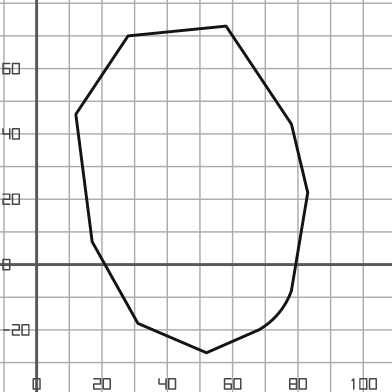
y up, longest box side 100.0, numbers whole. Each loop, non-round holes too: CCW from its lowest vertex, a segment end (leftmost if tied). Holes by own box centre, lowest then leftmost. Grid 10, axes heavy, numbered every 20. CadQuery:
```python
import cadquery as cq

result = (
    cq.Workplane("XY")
    .moveTo(52.0, -27.0)
    .lineTo(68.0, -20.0)
    .threePointArc((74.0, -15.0), (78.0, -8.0))
    .lineTo(83.0, 22.0)
    .lineTo(78.0, 43.0)
    .lineTo(58.0, 73.0)
    .lineTo(28.0, 70.0)
    .lineTo(12.0, 46.0)
    .lineTo(17.0, 7.0)
    .lineTo(31.0, -18.0)
    .close()
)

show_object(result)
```